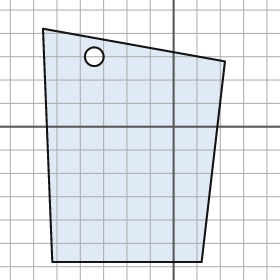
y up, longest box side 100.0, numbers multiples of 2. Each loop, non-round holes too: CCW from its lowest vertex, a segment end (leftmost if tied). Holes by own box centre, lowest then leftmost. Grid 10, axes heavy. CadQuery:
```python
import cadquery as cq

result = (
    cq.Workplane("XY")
    .moveTo(-52.0, -58.0)
    .lineTo(12.0, -58.0)
    .lineTo(22.0, 28.0)
    .lineTo(-56.0, 42.0)
    .close()
    .moveTo(-34.0, 30.0)
    .circle(4.0)
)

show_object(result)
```